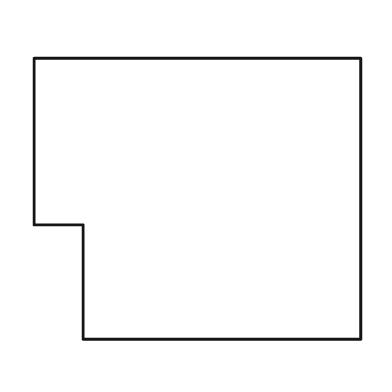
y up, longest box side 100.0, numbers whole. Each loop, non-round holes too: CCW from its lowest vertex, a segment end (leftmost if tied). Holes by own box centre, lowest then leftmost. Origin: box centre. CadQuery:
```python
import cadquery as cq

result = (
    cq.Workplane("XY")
    .moveTo(-35.0, -43.0)
    .lineTo(50.0, -43.0)
    .lineTo(50.0, 43.0)
    .lineTo(-50.0, 43.0)
    .lineTo(-50.0, -8.0)
    .lineTo(-35.0, -8.0)
    .close()
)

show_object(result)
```